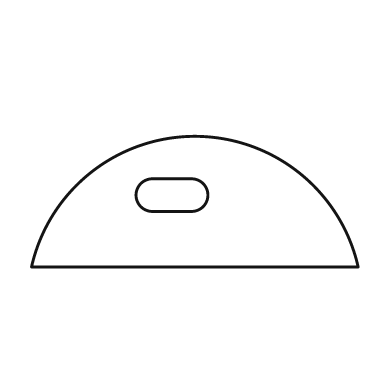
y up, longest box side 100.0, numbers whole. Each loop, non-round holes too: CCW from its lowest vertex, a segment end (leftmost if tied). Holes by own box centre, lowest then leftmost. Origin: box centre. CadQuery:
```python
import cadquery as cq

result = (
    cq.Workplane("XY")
    .moveTo(-50.0, -20.0)
    .lineTo(50.0, -20.0)
    .threePointArc((0.0, 20.0), (-50.0, -20.0))
    .close()
    .moveTo(-13.0, -3.0)
    .lineTo(-1.0, -3.0)
    .threePointArc((4.0, 2.0), (-1.0, 7.0))
    .lineTo(-13.0, 7.0)
    .threePointArc((-18.0, 2.0), (-13.0, -3.0))
    .close()
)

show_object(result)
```